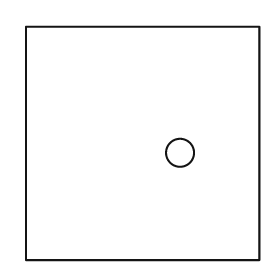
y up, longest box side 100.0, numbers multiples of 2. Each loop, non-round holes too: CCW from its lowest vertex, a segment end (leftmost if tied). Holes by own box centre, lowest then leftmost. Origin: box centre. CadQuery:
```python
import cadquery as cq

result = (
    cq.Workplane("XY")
    .moveTo(-50.0, -50.0)
    .lineTo(50.0, -50.0)
    .lineTo(50.0, 50.0)
    .lineTo(-50.0, 50.0)
    .close()
    .moveTo(16.0, -4.0)
    .circle(6.0)
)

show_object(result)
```